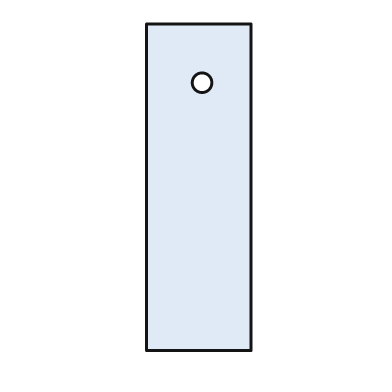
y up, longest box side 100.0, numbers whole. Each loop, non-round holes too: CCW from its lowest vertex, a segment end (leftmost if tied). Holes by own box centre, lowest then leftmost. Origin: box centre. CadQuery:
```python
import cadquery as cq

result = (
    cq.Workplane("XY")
    .moveTo(-16.0, -50.0)
    .lineTo(16.0, -50.0)
    .lineTo(16.0, 50.0)
    .lineTo(-16.0, 50.0)
    .close()
    .moveTo(1.0, 32.0)
    .circle(3.0)
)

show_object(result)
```